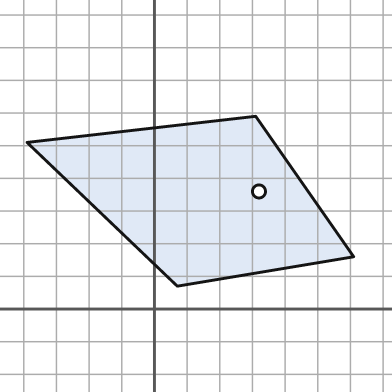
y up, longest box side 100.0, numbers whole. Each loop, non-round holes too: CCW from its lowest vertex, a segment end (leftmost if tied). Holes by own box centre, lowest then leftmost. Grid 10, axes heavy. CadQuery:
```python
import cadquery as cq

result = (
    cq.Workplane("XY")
    .moveTo(7.0, 7.0)
    .lineTo(61.0, 16.0)
    .lineTo(31.0, 59.0)
    .lineTo(-39.0, 51.0)
    .close()
    .moveTo(32.0, 36.0)
    .circle(2.0)
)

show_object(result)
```